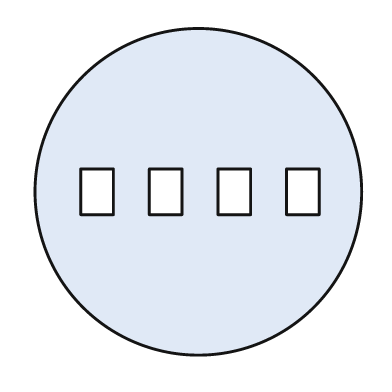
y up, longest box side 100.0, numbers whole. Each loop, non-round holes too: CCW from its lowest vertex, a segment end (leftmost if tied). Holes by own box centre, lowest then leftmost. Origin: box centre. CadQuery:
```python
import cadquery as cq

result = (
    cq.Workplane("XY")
    .moveTo(0.0, 0.0)
    .circle(50.0)
    .moveTo(-36.0, -7.0)
    .lineTo(-26.0, -7.0)
    .lineTo(-26.0, 7.0)
    .lineTo(-36.0, 7.0)
    .close()
    .moveTo(-15.0, -7.0)
    .lineTo(-5.0, -7.0)
    .lineTo(-5.0, 7.0)
    .lineTo(-15.0, 7.0)
    .close()
    .moveTo(6.0, -7.0)
    .lineTo(16.0, -7.0)
    .lineTo(16.0, 7.0)
    .lineTo(6.0, 7.0)
    .close()
    .moveTo(27.0, -7.0)
    .lineTo(37.0, -7.0)
    .lineTo(37.0, 7.0)
    .lineTo(27.0, 7.0)
    .close()
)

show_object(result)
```